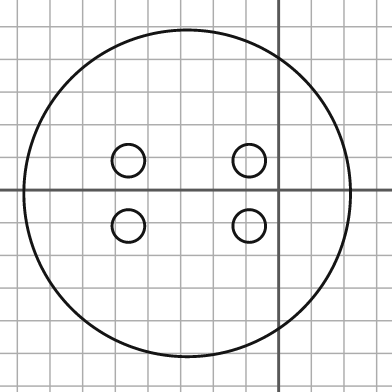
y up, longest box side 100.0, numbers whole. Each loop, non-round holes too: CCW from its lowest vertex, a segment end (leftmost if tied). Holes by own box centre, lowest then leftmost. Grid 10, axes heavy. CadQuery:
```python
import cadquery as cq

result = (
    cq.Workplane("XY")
    .moveTo(-28.0, -1.0)
    .circle(50.0)
    .moveTo(-46.0, -11.0)
    .circle(5.0)
    .moveTo(-9.0, -11.0)
    .circle(5.0)
    .moveTo(-46.0, 9.0)
    .circle(5.0)
    .moveTo(-9.0, 9.0)
    .circle(5.0)
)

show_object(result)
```